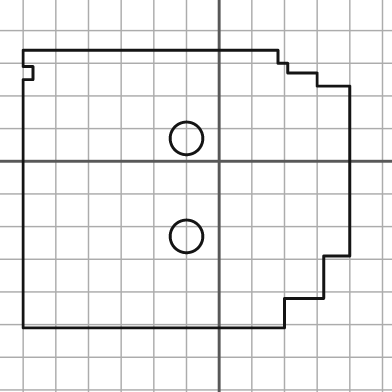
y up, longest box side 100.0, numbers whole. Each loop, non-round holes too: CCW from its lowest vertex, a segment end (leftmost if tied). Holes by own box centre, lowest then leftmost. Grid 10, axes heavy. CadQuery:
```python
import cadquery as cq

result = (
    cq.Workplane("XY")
    .moveTo(-60.0, -51.0)
    .lineTo(20.0, -51.0)
    .lineTo(20.0, -42.0)
    .lineTo(32.0, -42.0)
    .lineTo(32.0, -29.0)
    .lineTo(40.0, -29.0)
    .lineTo(40.0, 23.0)
    .lineTo(30.0, 23.0)
    .lineTo(30.0, 27.0)
    .lineTo(21.0, 27.0)
    .lineTo(21.0, 30.0)
    .lineTo(18.0, 30.0)
    .lineTo(18.0, 34.0)
    .lineTo(-60.0, 34.0)
    .lineTo(-60.0, 29.0)
    .lineTo(-57.0, 29.0)
    .lineTo(-57.0, 25.0)
    .lineTo(-60.0, 25.0)
    .close()
    .moveTo(-10.0, -23.0)
    .circle(5.0)
    .moveTo(-10.0, 7.0)
    .circle(5.0)
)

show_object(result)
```